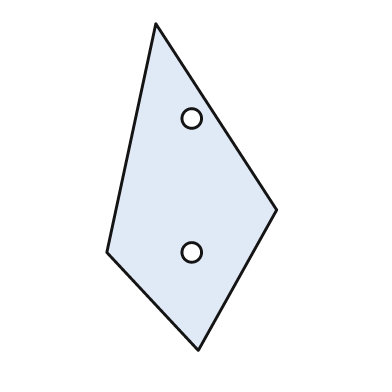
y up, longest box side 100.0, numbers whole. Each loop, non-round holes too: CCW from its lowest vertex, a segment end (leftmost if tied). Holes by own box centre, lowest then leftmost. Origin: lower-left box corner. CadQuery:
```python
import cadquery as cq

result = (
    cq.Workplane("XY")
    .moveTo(28.0, 0.0)
    .lineTo(52.0, 43.0)
    .lineTo(15.0, 100.0)
    .lineTo(0.0, 30.0)
    .close()
    .moveTo(26.0, 30.0)
    .circle(3.0)
    .moveTo(26.0, 71.0)
    .circle(3.0)
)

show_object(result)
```